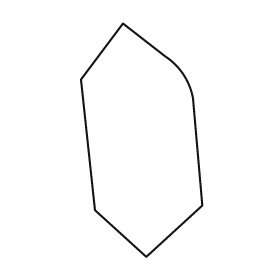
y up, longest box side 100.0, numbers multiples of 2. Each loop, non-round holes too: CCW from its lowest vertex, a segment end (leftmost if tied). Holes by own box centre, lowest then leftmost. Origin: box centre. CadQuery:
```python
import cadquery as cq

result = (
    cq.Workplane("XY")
    .moveTo(2.0, -50.0)
    .lineTo(26.0, -28.0)
    .lineTo(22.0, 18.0)
    .threePointArc((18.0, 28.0), (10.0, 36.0))
    .lineTo(-8.0, 50.0)
    .lineTo(-26.0, 26.0)
    .lineTo(-20.0, -30.0)
    .close()
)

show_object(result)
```